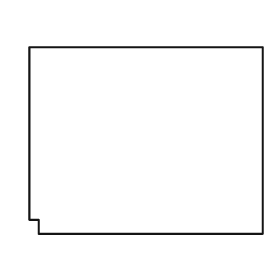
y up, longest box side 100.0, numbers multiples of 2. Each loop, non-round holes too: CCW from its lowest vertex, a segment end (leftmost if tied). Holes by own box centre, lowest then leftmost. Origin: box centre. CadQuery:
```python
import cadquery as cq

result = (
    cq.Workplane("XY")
    .moveTo(-46.0, -40.0)
    .lineTo(50.0, -40.0)
    .lineTo(50.0, 40.0)
    .lineTo(-50.0, 40.0)
    .lineTo(-50.0, -34.0)
    .lineTo(-46.0, -34.0)
    .close()
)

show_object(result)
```